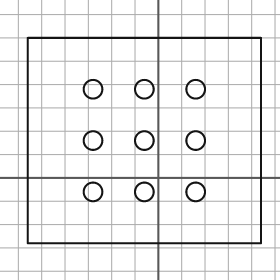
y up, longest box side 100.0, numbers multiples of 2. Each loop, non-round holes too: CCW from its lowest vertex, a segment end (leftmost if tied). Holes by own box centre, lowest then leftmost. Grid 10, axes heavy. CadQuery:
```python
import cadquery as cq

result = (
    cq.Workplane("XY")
    .moveTo(-56.0, -28.0)
    .lineTo(44.0, -28.0)
    .lineTo(44.0, 60.0)
    .lineTo(-56.0, 60.0)
    .close()
    .moveTo(-28.0, -6.0)
    .circle(4.0)
    .moveTo(-6.0, -6.0)
    .circle(4.0)
    .moveTo(16.0, -6.0)
    .circle(4.0)
    .moveTo(-28.0, 16.0)
    .circle(4.0)
    .moveTo(-6.0, 16.0)
    .circle(4.0)
    .moveTo(16.0, 16.0)
    .circle(4.0)
    .moveTo(-28.0, 38.0)
    .circle(4.0)
    .moveTo(-6.0, 38.0)
    .circle(4.0)
    .moveTo(16.0, 38.0)
    .circle(4.0)
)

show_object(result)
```